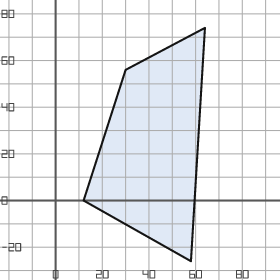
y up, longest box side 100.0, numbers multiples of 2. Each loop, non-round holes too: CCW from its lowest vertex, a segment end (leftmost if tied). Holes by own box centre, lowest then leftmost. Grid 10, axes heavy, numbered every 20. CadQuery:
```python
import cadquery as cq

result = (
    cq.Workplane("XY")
    .moveTo(58.0, -26.0)
    .lineTo(64.0, 74.0)
    .lineTo(30.0, 56.0)
    .lineTo(12.0, 0.0)
    .close()
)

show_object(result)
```